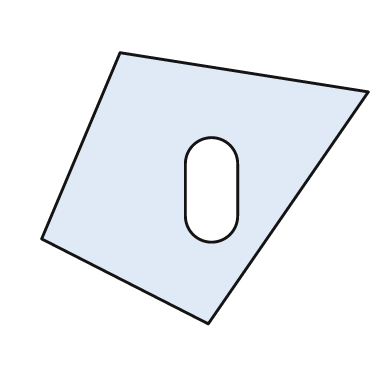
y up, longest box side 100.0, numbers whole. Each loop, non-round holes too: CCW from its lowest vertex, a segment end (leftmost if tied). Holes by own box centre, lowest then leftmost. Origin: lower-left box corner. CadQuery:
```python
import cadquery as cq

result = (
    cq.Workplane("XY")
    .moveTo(51.0, 0.0)
    .lineTo(100.0, 71.0)
    .lineTo(24.0, 83.0)
    .lineTo(0.0, 26.0)
    .close()
    .moveTo(44.0, 33.0)
    .threePointArc((52.0, 25.0), (60.0, 33.0))
    .lineTo(60.0, 49.0)
    .threePointArc((52.0, 57.0), (44.0, 49.0))
    .close()
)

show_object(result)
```